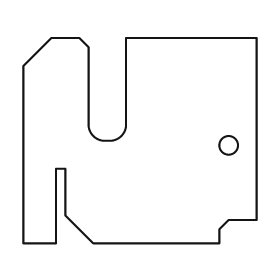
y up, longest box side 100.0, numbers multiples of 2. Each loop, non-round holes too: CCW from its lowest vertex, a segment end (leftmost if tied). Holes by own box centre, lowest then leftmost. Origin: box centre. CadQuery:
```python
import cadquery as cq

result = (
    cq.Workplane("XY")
    .moveTo(-50.0, -44.0)
    .lineTo(-36.0, -44.0)
    .lineTo(-36.0, -12.0)
    .lineTo(-32.0, -12.0)
    .lineTo(-32.0, -32.0)
    .lineTo(-20.0, -44.0)
    .lineTo(34.0, -44.0)
    .lineTo(34.0, -38.0)
    .lineTo(38.0, -34.0)
    .lineTo(50.0, -34.0)
    .lineTo(50.0, 44.0)
    .lineTo(-6.0, 44.0)
    .lineTo(-6.0, 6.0)
    .threePointArc((-8.0, 2.0), (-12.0, 0.0))
    .lineTo(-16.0, 0.0)
    .threePointArc((-20.0, 2.0), (-22.0, 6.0))
    .lineTo(-22.0, 40.0)
    .lineTo(-26.0, 44.0)
    .lineTo(-38.0, 44.0)
    .lineTo(-50.0, 32.0)
    .close()
    .moveTo(38.0, -2.0)
    .circle(4.0)
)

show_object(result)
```